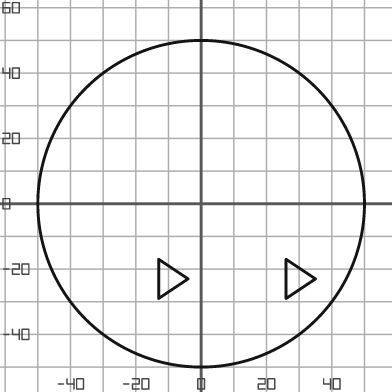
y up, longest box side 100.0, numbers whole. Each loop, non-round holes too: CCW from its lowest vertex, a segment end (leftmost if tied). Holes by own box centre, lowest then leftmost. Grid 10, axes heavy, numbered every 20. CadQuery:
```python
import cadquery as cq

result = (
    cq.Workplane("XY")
    .moveTo(0.0, 0.0)
    .circle(50.0)
    .moveTo(-13.0, -29.0)
    .lineTo(-4.0, -23.0)
    .lineTo(-13.0, -17.0)
    .close()
    .moveTo(26.0, -29.0)
    .lineTo(35.0, -23.0)
    .lineTo(26.0, -17.0)
    .close()
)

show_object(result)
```